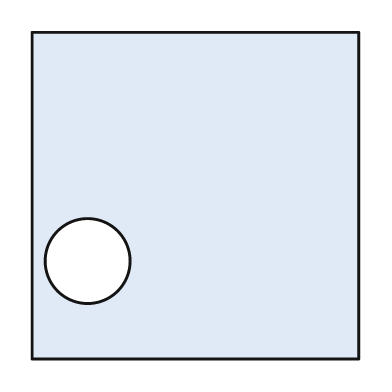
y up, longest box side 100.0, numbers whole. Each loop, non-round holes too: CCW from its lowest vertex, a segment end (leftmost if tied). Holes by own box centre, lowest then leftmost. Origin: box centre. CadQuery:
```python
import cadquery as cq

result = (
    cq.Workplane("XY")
    .moveTo(-50.0, -50.0)
    .lineTo(50.0, -50.0)
    .lineTo(50.0, 50.0)
    .lineTo(-50.0, 50.0)
    .close()
    .moveTo(-33.0, -20.0)
    .circle(13.0)
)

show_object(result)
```